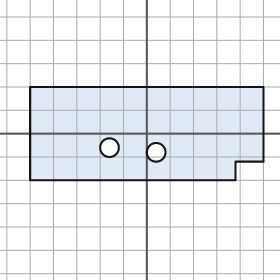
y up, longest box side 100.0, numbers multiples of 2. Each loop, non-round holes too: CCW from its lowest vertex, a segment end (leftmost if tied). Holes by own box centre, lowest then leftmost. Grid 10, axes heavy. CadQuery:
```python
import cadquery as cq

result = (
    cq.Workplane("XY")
    .moveTo(-50.0, -20.0)
    .lineTo(38.0, -20.0)
    .lineTo(38.0, -12.0)
    .lineTo(50.0, -12.0)
    .lineTo(50.0, 20.0)
    .lineTo(-50.0, 20.0)
    .close()
    .moveTo(4.0, -8.0)
    .circle(4.0)
    .moveTo(-16.0, -6.0)
    .circle(4.0)
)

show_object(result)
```